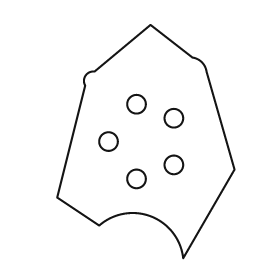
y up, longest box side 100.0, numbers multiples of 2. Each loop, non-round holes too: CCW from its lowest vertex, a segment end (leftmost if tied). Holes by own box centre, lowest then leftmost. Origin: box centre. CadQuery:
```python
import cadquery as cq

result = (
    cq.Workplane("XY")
    .moveTo(16.0, -50.0)
    .lineTo(38.0, -12.0)
    .lineTo(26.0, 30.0)
    .threePointArc((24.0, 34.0), (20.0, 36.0))
    .lineTo(2.0, 50.0)
    .lineTo(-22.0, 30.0)
    .threePointArc((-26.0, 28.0), (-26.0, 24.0))
    .lineTo(-38.0, -24.0)
    .lineTo(-20.0, -36.0)
    .threePointArc((2.0, -32.0), (16.0, -50.0))
    .close()
    .moveTo(-4.0, -16.0)
    .circle(4.0)
    .moveTo(12.0, -10.0)
    .circle(4.0)
    .moveTo(-16.0, 0.0)
    .circle(4.0)
    .moveTo(12.0, 10.0)
    .circle(4.0)
    .moveTo(-4.0, 16.0)
    .circle(4.0)
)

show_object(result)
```